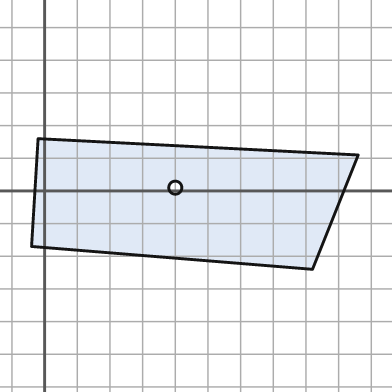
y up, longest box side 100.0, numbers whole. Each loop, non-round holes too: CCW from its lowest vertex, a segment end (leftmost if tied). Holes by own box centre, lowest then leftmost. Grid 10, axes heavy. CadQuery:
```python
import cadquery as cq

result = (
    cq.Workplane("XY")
    .moveTo(82.0, -24.0)
    .lineTo(96.0, 11.0)
    .lineTo(-2.0, 16.0)
    .lineTo(-4.0, -17.0)
    .close()
    .moveTo(40.0, 1.0)
    .circle(2.0)
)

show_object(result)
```